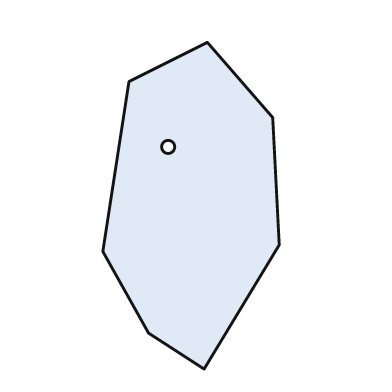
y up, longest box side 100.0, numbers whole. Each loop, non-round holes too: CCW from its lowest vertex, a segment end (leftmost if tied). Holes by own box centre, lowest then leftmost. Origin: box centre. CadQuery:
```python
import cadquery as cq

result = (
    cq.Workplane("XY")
    .moveTo(4.0, -50.0)
    .lineTo(27.0, -12.0)
    .lineTo(25.0, 27.0)
    .lineTo(5.0, 50.0)
    .lineTo(-19.0, 38.0)
    .lineTo(-27.0, -14.0)
    .lineTo(-13.0, -39.0)
    .close()
    .moveTo(-7.0, 18.0)
    .circle(2.0)
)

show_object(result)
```